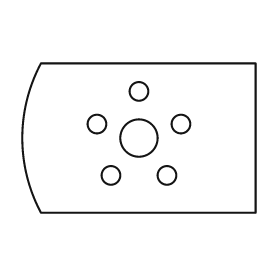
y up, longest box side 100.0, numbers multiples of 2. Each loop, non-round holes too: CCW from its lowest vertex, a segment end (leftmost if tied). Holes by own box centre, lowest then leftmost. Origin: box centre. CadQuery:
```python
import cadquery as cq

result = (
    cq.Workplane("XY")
    .moveTo(-42.0, -32.0)
    .lineTo(50.0, -32.0)
    .lineTo(50.0, 32.0)
    .lineTo(-42.0, 32.0)
    .threePointArc((-50.0, 0.0), (-42.0, -32.0))
    .close()
    .moveTo(-12.0, -16.0)
    .circle(4.0)
    .moveTo(12.0, -16.0)
    .circle(4.0)
    .moveTo(0.0, 0.0)
    .circle(8.0)
    .moveTo(-18.0, 6.0)
    .circle(4.0)
    .moveTo(18.0, 6.0)
    .circle(4.0)
    .moveTo(0.0, 20.0)
    .circle(4.0)
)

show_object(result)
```